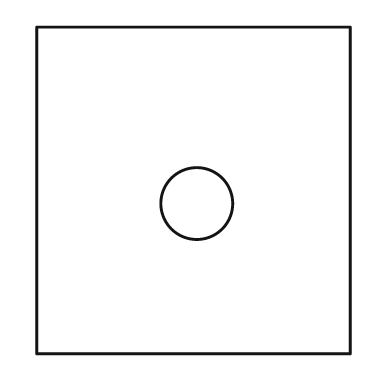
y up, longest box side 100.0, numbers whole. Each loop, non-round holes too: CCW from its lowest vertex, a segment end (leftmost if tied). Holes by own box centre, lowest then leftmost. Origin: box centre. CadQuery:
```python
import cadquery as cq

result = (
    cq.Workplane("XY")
    .moveTo(-48.0, -50.0)
    .lineTo(48.0, -50.0)
    .lineTo(48.0, 50.0)
    .lineTo(-48.0, 50.0)
    .close()
    .moveTo(1.0, -4.0)
    .circle(11.0)
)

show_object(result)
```